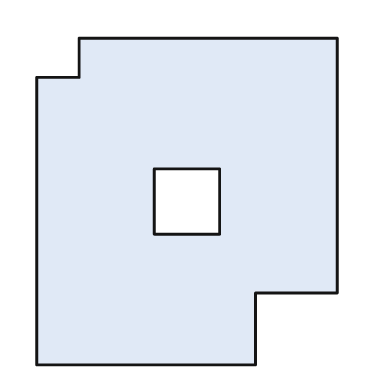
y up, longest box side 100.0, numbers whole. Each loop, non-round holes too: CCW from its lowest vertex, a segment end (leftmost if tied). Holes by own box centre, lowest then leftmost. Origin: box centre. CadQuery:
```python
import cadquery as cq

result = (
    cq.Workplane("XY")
    .moveTo(-46.0, -50.0)
    .lineTo(21.0, -50.0)
    .lineTo(21.0, -28.0)
    .lineTo(46.0, -28.0)
    .lineTo(46.0, 50.0)
    .lineTo(-33.0, 50.0)
    .lineTo(-33.0, 38.0)
    .lineTo(-46.0, 38.0)
    .close()
    .moveTo(-10.0, -10.0)
    .lineTo(10.0, -10.0)
    .lineTo(10.0, 10.0)
    .lineTo(-10.0, 10.0)
    .close()
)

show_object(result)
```